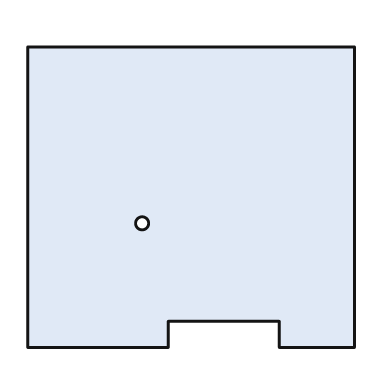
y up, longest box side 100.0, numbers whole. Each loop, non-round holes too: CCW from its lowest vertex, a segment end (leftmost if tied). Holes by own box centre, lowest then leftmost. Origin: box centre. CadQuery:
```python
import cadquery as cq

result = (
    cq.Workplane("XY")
    .moveTo(-50.0, -46.0)
    .lineTo(-7.0, -46.0)
    .lineTo(-7.0, -38.0)
    .lineTo(27.0, -38.0)
    .lineTo(27.0, -46.0)
    .lineTo(50.0, -46.0)
    .lineTo(50.0, 46.0)
    .lineTo(-50.0, 46.0)
    .close()
    .moveTo(-15.0, -8.0)
    .circle(2.0)
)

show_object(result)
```